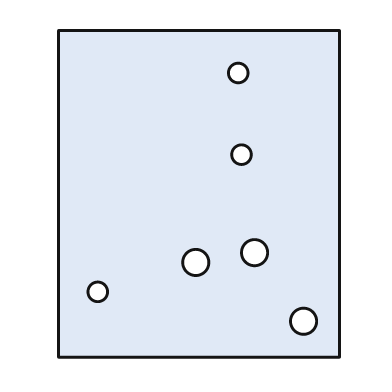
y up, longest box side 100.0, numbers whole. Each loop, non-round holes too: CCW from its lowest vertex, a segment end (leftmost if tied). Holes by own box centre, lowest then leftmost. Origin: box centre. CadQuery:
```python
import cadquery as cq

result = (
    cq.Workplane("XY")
    .moveTo(-43.0, -50.0)
    .lineTo(43.0, -50.0)
    .lineTo(43.0, 50.0)
    .lineTo(-43.0, 50.0)
    .close()
    .moveTo(32.0, -39.0)
    .circle(4.0)
    .moveTo(-31.0, -30.0)
    .circle(3.0)
    .moveTo(-1.0, -21.0)
    .circle(4.0)
    .moveTo(17.0, -18.0)
    .circle(4.0)
    .moveTo(13.0, 12.0)
    .circle(3.0)
    .moveTo(12.0, 37.0)
    .circle(3.0)
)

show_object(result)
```